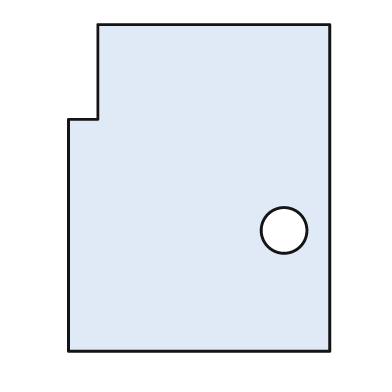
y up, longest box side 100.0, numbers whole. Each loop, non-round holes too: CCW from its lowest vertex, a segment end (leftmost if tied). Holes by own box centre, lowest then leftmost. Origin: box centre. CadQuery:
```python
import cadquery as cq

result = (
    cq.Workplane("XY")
    .moveTo(-40.0, -50.0)
    .lineTo(40.0, -50.0)
    .lineTo(40.0, 50.0)
    .lineTo(-31.0, 50.0)
    .lineTo(-31.0, 21.0)
    .lineTo(-40.0, 21.0)
    .close()
    .moveTo(26.0, -13.0)
    .circle(7.0)
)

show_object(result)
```